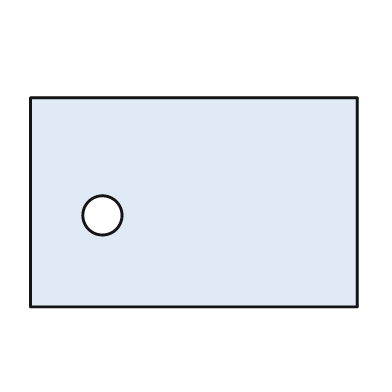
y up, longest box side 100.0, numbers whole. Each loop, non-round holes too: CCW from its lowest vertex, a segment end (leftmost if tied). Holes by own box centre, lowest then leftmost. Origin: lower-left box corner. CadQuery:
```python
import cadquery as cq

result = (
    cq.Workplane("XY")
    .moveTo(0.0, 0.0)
    .lineTo(100.0, 0.0)
    .lineTo(100.0, 64.0)
    .lineTo(0.0, 64.0)
    .close()
    .moveTo(22.0, 28.0)
    .circle(6.0)
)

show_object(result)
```